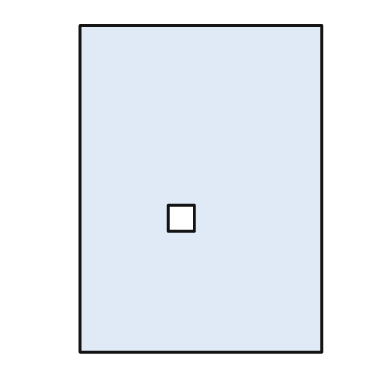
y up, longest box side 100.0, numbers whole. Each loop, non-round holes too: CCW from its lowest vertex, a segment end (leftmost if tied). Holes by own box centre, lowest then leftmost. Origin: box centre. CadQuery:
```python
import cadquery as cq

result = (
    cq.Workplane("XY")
    .moveTo(-37.0, -50.0)
    .lineTo(37.0, -50.0)
    .lineTo(37.0, 50.0)
    .lineTo(-37.0, 50.0)
    .close()
    .moveTo(-10.0, -13.0)
    .lineTo(-2.0, -13.0)
    .lineTo(-2.0, -5.0)
    .lineTo(-10.0, -5.0)
    .close()
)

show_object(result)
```